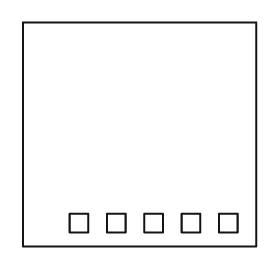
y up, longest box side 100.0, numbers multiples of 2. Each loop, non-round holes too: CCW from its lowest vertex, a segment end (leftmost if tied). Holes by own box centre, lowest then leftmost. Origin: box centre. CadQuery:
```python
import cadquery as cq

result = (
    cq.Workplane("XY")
    .moveTo(-50.0, -48.0)
    .lineTo(50.0, -48.0)
    .lineTo(50.0, 48.0)
    .lineTo(-50.0, 48.0)
    .close()
    .moveTo(-30.0, -42.0)
    .lineTo(-22.0, -42.0)
    .lineTo(-22.0, -34.0)
    .lineTo(-30.0, -34.0)
    .close()
    .moveTo(-14.0, -42.0)
    .lineTo(-6.0, -42.0)
    .lineTo(-6.0, -34.0)
    .lineTo(-14.0, -34.0)
    .close()
    .moveTo(2.0, -42.0)
    .lineTo(10.0, -42.0)
    .lineTo(10.0, -34.0)
    .lineTo(2.0, -34.0)
    .close()
    .moveTo(18.0, -42.0)
    .lineTo(26.0, -42.0)
    .lineTo(26.0, -34.0)
    .lineTo(18.0, -34.0)
    .close()
    .moveTo(34.0, -42.0)
    .lineTo(42.0, -42.0)
    .lineTo(42.0, -34.0)
    .lineTo(34.0, -34.0)
    .close()
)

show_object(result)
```